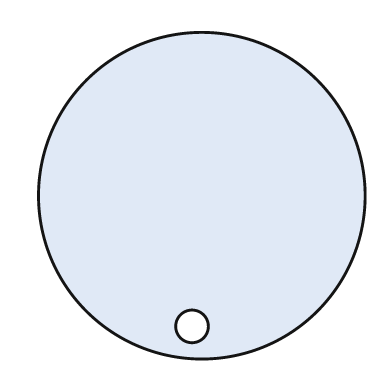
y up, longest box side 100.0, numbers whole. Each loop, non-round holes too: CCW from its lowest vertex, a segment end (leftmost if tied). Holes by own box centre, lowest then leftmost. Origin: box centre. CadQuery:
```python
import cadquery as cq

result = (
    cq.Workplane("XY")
    .moveTo(0.0, 0.0)
    .circle(50.0)
    .moveTo(-3.0, -40.0)
    .circle(5.0)
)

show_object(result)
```